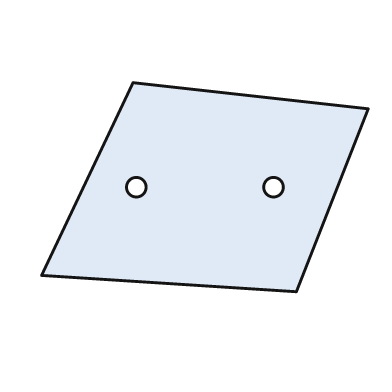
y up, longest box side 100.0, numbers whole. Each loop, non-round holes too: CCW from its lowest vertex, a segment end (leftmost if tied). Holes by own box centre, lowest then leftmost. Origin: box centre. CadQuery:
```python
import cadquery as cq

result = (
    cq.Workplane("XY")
    .moveTo(28.0, -32.0)
    .lineTo(50.0, 24.0)
    .lineTo(-22.0, 32.0)
    .lineTo(-50.0, -27.0)
    .close()
    .moveTo(-21.0, 0.0)
    .circle(3.0)
    .moveTo(21.0, 0.0)
    .circle(3.0)
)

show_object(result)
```